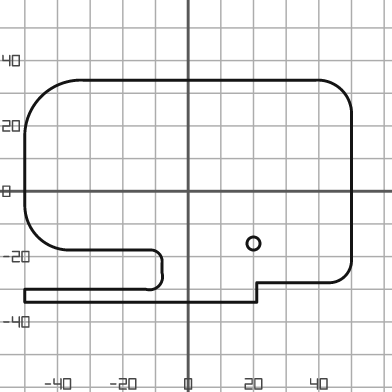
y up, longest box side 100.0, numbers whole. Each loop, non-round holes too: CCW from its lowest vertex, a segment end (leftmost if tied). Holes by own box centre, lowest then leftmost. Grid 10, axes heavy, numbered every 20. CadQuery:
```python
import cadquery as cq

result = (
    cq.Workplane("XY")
    .moveTo(-50.0, -34.0)
    .lineTo(21.0, -34.0)
    .lineTo(21.0, -28.0)
    .lineTo(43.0, -28.0)
    .threePointArc((48.0, -26.0), (50.0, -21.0))
    .lineTo(50.0, 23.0)
    .threePointArc((47.0, 31.0), (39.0, 34.0))
    .lineTo(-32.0, 34.0)
    .threePointArc((-45.0, 29.0), (-50.0, 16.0))
    .lineTo(-50.0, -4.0)
    .threePointArc((-46.0, -14.0), (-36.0, -18.0))
    .lineTo(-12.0, -18.0)
    .threePointArc((-9.0, -19.0), (-8.0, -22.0))
    .lineTo(-8.0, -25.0)
    .threePointArc((-9.0, -29.0), (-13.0, -30.0))
    .lineTo(-50.0, -30.0)
    .close()
    .moveTo(20.0, -16.0)
    .circle(2.0)
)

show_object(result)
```